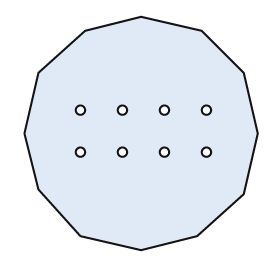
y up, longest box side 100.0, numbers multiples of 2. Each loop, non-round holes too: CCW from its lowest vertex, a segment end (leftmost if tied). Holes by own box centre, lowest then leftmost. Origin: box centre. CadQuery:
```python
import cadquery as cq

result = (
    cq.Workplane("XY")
    .moveTo(0.0, -50.0)
    .lineTo(24.0, -44.0)
    .lineTo(44.0, -26.0)
    .lineTo(50.0, 0.0)
    .lineTo(44.0, 26.0)
    .lineTo(26.0, 44.0)
    .lineTo(0.0, 50.0)
    .lineTo(-24.0, 44.0)
    .lineTo(-44.0, 26.0)
    .lineTo(-50.0, 0.0)
    .lineTo(-44.0, -24.0)
    .lineTo(-26.0, -44.0)
    .close()
    .moveTo(-26.0, -8.0)
    .circle(2.0)
    .moveTo(-8.0, -8.0)
    .circle(2.0)
    .moveTo(10.0, -8.0)
    .circle(2.0)
    .moveTo(28.0, -8.0)
    .circle(2.0)
    .moveTo(-26.0, 10.0)
    .circle(2.0)
    .moveTo(-8.0, 10.0)
    .circle(2.0)
    .moveTo(10.0, 10.0)
    .circle(2.0)
    .moveTo(28.0, 10.0)
    .circle(2.0)
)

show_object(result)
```